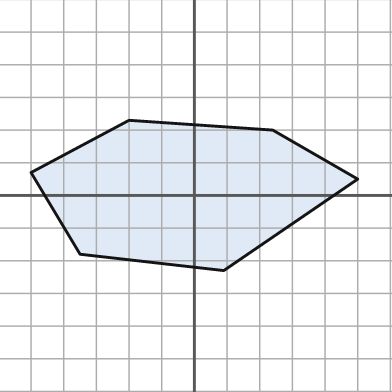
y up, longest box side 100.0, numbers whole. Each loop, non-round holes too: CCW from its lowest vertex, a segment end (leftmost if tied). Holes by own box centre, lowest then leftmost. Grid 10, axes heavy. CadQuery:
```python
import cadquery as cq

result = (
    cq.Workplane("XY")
    .moveTo(9.0, -23.0)
    .lineTo(50.0, 5.0)
    .lineTo(24.0, 20.0)
    .lineTo(-20.0, 23.0)
    .lineTo(-50.0, 7.0)
    .lineTo(-35.0, -18.0)
    .close()
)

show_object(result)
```